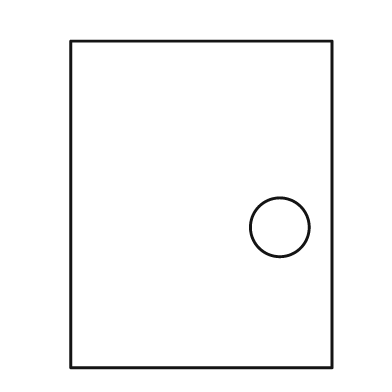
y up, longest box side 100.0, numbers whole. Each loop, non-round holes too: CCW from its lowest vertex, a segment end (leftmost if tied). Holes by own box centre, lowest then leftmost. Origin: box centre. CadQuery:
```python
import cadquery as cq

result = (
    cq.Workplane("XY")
    .moveTo(-40.0, -50.0)
    .lineTo(40.0, -50.0)
    .lineTo(40.0, 50.0)
    .lineTo(-40.0, 50.0)
    .close()
    .moveTo(24.0, -7.0)
    .circle(9.0)
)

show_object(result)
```